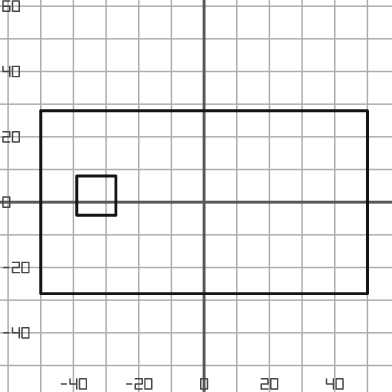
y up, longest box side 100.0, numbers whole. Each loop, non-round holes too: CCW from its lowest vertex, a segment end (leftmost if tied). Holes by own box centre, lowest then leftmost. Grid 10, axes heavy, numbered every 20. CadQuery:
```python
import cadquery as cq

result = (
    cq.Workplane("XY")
    .moveTo(-50.0, -28.0)
    .lineTo(50.0, -28.0)
    .lineTo(50.0, 28.0)
    .lineTo(-50.0, 28.0)
    .close()
    .moveTo(-39.0, -4.0)
    .lineTo(-27.0, -4.0)
    .lineTo(-27.0, 8.0)
    .lineTo(-39.0, 8.0)
    .close()
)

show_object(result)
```